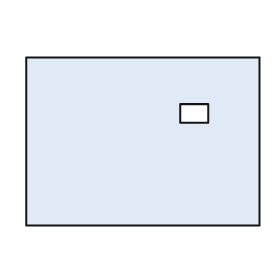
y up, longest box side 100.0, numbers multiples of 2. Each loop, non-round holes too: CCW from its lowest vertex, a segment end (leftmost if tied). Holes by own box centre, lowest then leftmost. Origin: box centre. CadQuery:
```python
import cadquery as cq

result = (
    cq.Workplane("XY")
    .moveTo(-50.0, -36.0)
    .lineTo(50.0, -36.0)
    .lineTo(50.0, 36.0)
    .lineTo(-50.0, 36.0)
    .close()
    .moveTo(16.0, 8.0)
    .lineTo(28.0, 8.0)
    .lineTo(28.0, 16.0)
    .lineTo(16.0, 16.0)
    .close()
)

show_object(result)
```